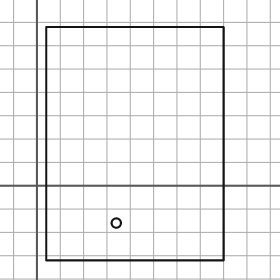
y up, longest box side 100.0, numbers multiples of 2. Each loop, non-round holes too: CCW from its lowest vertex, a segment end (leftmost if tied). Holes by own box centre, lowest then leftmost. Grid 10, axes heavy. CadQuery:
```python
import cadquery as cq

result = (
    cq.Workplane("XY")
    .moveTo(4.0, -32.0)
    .lineTo(80.0, -32.0)
    .lineTo(80.0, 68.0)
    .lineTo(4.0, 68.0)
    .close()
    .moveTo(34.0, -16.0)
    .circle(2.0)
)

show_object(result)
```